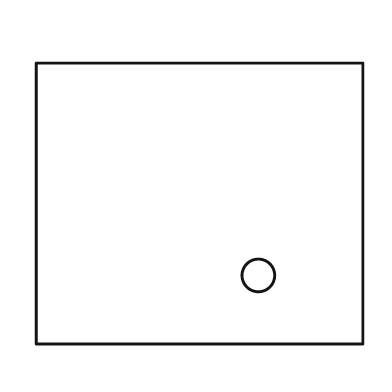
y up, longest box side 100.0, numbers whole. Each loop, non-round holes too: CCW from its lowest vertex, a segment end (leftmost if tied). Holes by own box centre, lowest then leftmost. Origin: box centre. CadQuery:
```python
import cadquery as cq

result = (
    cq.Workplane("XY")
    .moveTo(-50.0, -43.0)
    .lineTo(50.0, -43.0)
    .lineTo(50.0, 43.0)
    .lineTo(-50.0, 43.0)
    .close()
    .moveTo(18.0, -22.0)
    .circle(5.0)
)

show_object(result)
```